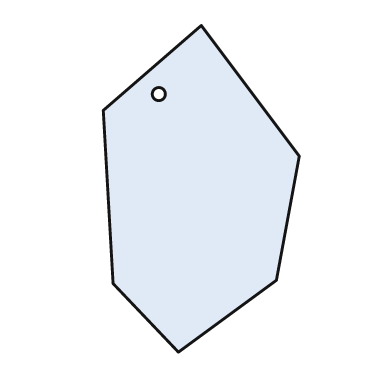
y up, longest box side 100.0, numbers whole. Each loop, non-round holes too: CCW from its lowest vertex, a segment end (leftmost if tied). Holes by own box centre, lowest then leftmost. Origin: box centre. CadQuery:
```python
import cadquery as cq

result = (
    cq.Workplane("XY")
    .moveTo(-7.0, -50.0)
    .lineTo(23.0, -28.0)
    .lineTo(30.0, 10.0)
    .lineTo(0.0, 50.0)
    .lineTo(-30.0, 24.0)
    .lineTo(-27.0, -29.0)
    .close()
    .moveTo(-13.0, 29.0)
    .circle(2.0)
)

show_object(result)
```